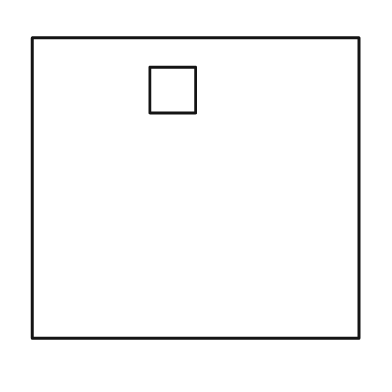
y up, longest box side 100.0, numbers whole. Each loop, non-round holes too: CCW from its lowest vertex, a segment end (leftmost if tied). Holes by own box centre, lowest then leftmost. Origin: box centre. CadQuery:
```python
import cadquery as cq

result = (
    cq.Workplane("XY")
    .moveTo(-50.0, -46.0)
    .lineTo(50.0, -46.0)
    .lineTo(50.0, 46.0)
    .lineTo(-50.0, 46.0)
    .close()
    .moveTo(-14.0, 23.0)
    .lineTo(0.0, 23.0)
    .lineTo(0.0, 37.0)
    .lineTo(-14.0, 37.0)
    .close()
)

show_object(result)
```